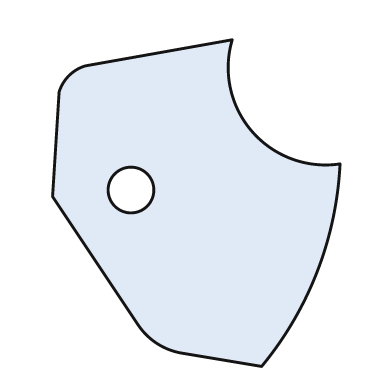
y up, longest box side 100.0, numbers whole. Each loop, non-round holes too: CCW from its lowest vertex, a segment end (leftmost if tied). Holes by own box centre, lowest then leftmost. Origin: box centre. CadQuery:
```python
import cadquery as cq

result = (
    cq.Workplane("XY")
    .moveTo(20.0, -50.0)
    .threePointArc((37.0, -21.0), (44.0, 12.0))
    .threePointArc((17.0, 22.0), (11.0, 50.0))
    .lineTo(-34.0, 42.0)
    .threePointArc((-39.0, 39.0), (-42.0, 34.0))
    .lineTo(-44.0, 2.0)
    .lineTo(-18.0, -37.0)
    .threePointArc((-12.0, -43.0), (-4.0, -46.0))
    .close()
    .moveTo(-20.0, 4.0)
    .circle(7.0)
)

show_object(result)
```